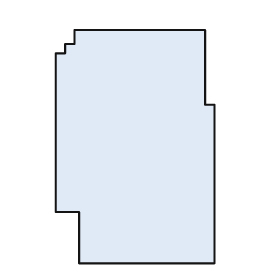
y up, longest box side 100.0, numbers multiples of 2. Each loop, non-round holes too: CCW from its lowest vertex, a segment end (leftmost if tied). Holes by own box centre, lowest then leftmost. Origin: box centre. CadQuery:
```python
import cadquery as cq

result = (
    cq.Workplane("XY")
    .moveTo(-24.0, -50.0)
    .lineTo(34.0, -50.0)
    .lineTo(34.0, 18.0)
    .lineTo(30.0, 18.0)
    .lineTo(30.0, 50.0)
    .lineTo(-26.0, 50.0)
    .lineTo(-26.0, 44.0)
    .lineTo(-30.0, 44.0)
    .lineTo(-30.0, 40.0)
    .lineTo(-34.0, 40.0)
    .lineTo(-34.0, -28.0)
    .lineTo(-24.0, -28.0)
    .close()
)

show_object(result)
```